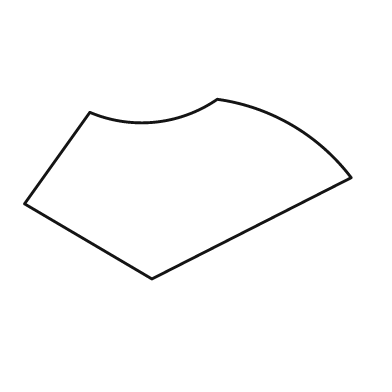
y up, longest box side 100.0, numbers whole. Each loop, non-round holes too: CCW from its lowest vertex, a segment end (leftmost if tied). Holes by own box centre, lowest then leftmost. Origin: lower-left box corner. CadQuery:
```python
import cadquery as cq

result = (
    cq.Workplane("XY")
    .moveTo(39.0, 0.0)
    .lineTo(100.0, 31.0)
    .threePointArc((82.0, 47.0), (59.0, 55.0))
    .threePointArc((40.0, 48.0), (20.0, 51.0))
    .lineTo(0.0, 23.0)
    .close()
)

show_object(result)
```